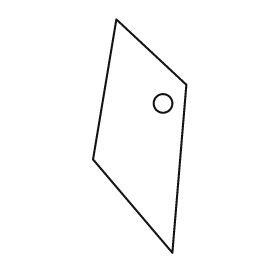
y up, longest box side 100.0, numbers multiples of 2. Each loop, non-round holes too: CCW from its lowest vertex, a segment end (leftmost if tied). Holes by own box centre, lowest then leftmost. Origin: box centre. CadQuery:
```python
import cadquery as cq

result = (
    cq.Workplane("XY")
    .moveTo(14.0, -50.0)
    .lineTo(20.0, 22.0)
    .lineTo(-10.0, 50.0)
    .lineTo(-20.0, -10.0)
    .close()
    .moveTo(10.0, 14.0)
    .circle(4.0)
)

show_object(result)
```